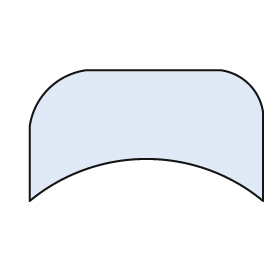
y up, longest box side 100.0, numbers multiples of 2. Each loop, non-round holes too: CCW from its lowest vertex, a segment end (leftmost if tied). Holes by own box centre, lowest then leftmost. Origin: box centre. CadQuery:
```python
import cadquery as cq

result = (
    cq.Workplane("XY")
    .moveTo(-50.0, -28.0)
    .threePointArc((0.0, -10.0), (50.0, -28.0))
    .lineTo(50.0, 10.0)
    .threePointArc((44.0, 22.0), (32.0, 28.0))
    .lineTo(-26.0, 28.0)
    .threePointArc((-42.0, 20.0), (-50.0, 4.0))
    .close()
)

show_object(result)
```